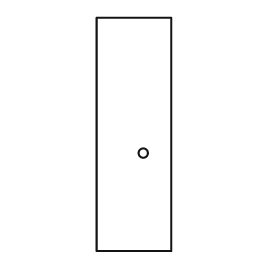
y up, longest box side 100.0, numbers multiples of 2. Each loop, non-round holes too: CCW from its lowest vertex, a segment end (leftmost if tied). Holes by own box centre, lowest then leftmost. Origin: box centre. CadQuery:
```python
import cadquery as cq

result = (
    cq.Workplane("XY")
    .moveTo(-16.0, -50.0)
    .lineTo(16.0, -50.0)
    .lineTo(16.0, 50.0)
    .lineTo(-16.0, 50.0)
    .close()
    .moveTo(4.0, -8.0)
    .circle(2.0)
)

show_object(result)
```